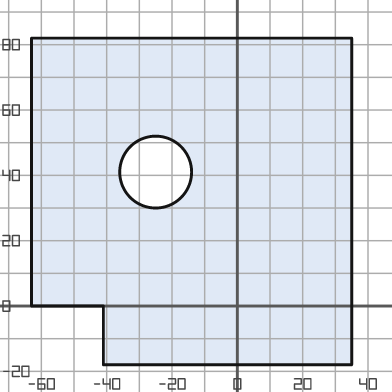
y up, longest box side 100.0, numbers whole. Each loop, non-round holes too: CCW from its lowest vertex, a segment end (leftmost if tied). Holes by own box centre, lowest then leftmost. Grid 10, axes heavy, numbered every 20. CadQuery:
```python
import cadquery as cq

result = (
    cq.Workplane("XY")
    .moveTo(-41.0, -18.0)
    .lineTo(35.0, -18.0)
    .lineTo(35.0, 82.0)
    .lineTo(-63.0, 82.0)
    .lineTo(-63.0, 0.0)
    .lineTo(-41.0, 0.0)
    .close()
    .moveTo(-25.0, 41.0)
    .circle(11.0)
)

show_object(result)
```